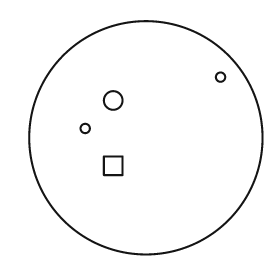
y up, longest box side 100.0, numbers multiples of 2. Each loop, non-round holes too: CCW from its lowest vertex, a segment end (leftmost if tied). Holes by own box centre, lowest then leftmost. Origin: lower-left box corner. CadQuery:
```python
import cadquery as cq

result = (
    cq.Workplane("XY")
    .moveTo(50.0, 50.0)
    .circle(50.0)
    .moveTo(32.0, 34.0)
    .lineTo(40.0, 34.0)
    .lineTo(40.0, 42.0)
    .lineTo(32.0, 42.0)
    .close()
    .moveTo(24.0, 54.0)
    .circle(2.0)
    .moveTo(36.0, 66.0)
    .circle(4.0)
    .moveTo(82.0, 76.0)
    .circle(2.0)
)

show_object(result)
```